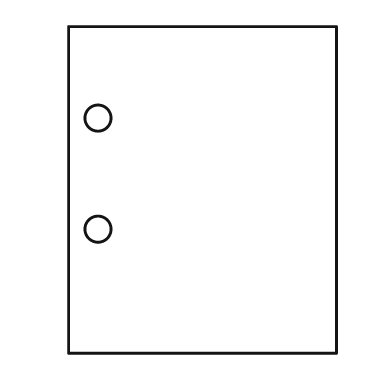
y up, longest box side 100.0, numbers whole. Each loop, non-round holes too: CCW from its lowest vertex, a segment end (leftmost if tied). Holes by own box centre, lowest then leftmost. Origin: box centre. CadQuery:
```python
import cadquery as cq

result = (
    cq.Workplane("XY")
    .moveTo(-41.0, -50.0)
    .lineTo(41.0, -50.0)
    .lineTo(41.0, 50.0)
    .lineTo(-41.0, 50.0)
    .close()
    .moveTo(-32.0, -12.0)
    .circle(4.0)
    .moveTo(-32.0, 22.0)
    .circle(4.0)
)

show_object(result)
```